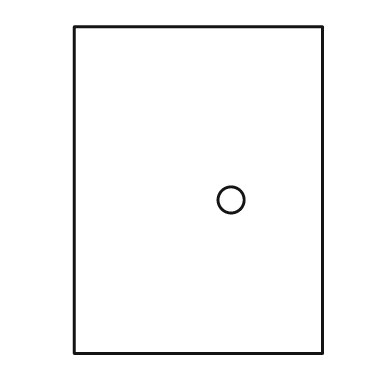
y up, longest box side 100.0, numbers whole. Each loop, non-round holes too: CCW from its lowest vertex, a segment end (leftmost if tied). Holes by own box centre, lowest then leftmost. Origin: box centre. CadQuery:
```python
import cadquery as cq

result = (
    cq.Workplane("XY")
    .moveTo(-38.0, -50.0)
    .lineTo(38.0, -50.0)
    .lineTo(38.0, 50.0)
    .lineTo(-38.0, 50.0)
    .close()
    .moveTo(10.0, -3.0)
    .circle(4.0)
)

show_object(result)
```